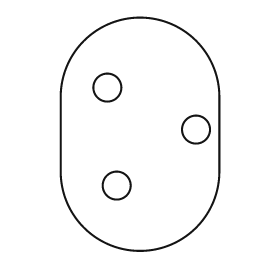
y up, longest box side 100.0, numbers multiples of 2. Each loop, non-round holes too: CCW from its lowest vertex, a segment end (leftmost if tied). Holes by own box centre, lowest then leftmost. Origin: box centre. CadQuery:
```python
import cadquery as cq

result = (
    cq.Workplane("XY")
    .moveTo(-34.0, -16.0)
    .threePointArc((0.0, -50.0), (34.0, -16.0))
    .lineTo(34.0, 16.0)
    .threePointArc((0.0, 50.0), (-34.0, 16.0))
    .close()
    .moveTo(-10.0, -22.0)
    .circle(6.0)
    .moveTo(24.0, 2.0)
    .circle(6.0)
    .moveTo(-14.0, 20.0)
    .circle(6.0)
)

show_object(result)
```